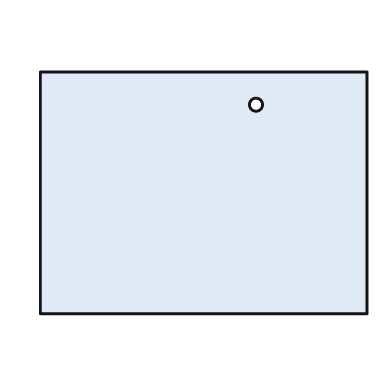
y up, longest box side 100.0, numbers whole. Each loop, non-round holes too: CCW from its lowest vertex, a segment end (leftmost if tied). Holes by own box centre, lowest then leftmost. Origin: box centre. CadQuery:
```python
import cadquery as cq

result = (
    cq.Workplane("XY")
    .moveTo(-50.0, -37.0)
    .lineTo(50.0, -37.0)
    .lineTo(50.0, 37.0)
    .lineTo(-50.0, 37.0)
    .close()
    .moveTo(16.0, 27.0)
    .circle(2.0)
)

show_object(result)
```